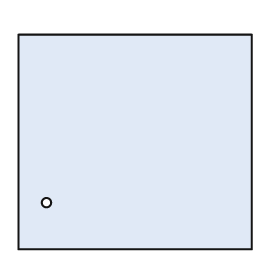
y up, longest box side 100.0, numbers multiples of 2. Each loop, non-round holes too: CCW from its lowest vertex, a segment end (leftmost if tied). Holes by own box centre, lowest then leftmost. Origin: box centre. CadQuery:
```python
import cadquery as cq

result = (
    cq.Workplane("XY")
    .moveTo(-50.0, -46.0)
    .lineTo(50.0, -46.0)
    .lineTo(50.0, 46.0)
    .lineTo(-50.0, 46.0)
    .close()
    .moveTo(-38.0, -26.0)
    .circle(2.0)
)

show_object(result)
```